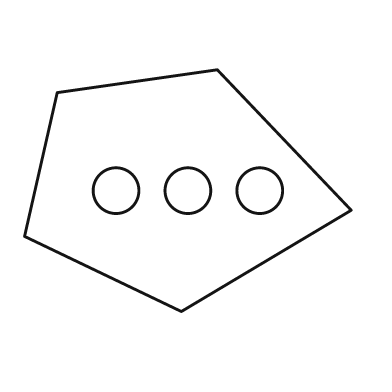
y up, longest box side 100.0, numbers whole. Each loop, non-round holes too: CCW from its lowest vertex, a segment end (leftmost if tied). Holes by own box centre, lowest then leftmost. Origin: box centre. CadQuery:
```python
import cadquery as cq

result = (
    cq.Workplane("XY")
    .moveTo(-2.0, -37.0)
    .lineTo(50.0, -6.0)
    .lineTo(9.0, 37.0)
    .lineTo(-40.0, 30.0)
    .lineTo(-50.0, -14.0)
    .close()
    .moveTo(-22.0, 0.0)
    .circle(7.0)
    .moveTo(0.0, 0.0)
    .circle(7.0)
    .moveTo(22.0, 0.0)
    .circle(7.0)
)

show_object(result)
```